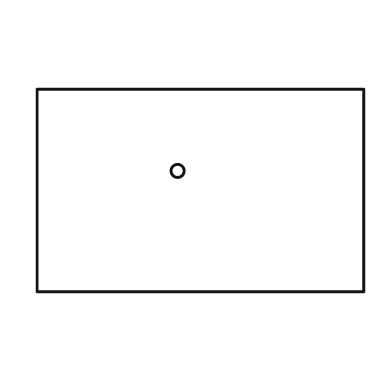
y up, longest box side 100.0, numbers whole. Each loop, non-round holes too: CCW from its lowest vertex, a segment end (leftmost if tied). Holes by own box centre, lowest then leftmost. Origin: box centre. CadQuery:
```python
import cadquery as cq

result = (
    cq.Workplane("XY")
    .moveTo(-50.0, -31.0)
    .lineTo(50.0, -31.0)
    .lineTo(50.0, 31.0)
    .lineTo(-50.0, 31.0)
    .close()
    .moveTo(-7.0, 6.0)
    .circle(2.0)
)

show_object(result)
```